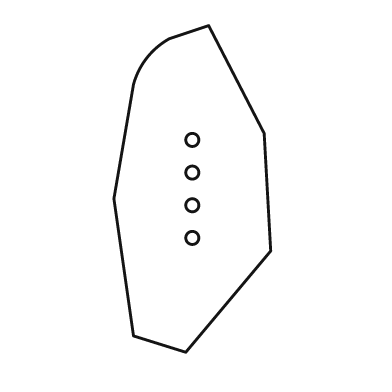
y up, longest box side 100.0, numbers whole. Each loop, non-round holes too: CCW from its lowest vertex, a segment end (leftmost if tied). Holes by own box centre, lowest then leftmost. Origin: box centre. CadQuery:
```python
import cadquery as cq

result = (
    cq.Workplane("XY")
    .moveTo(-2.0, -50.0)
    .lineTo(24.0, -19.0)
    .lineTo(22.0, 17.0)
    .lineTo(5.0, 50.0)
    .lineTo(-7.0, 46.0)
    .threePointArc((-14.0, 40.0), (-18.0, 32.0))
    .lineTo(-24.0, -3.0)
    .lineTo(-18.0, -45.0)
    .close()
    .moveTo(0.0, -15.0)
    .circle(2.0)
    .moveTo(0.0, -5.0)
    .circle(2.0)
    .moveTo(0.0, 5.0)
    .circle(2.0)
    .moveTo(0.0, 15.0)
    .circle(2.0)
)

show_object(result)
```